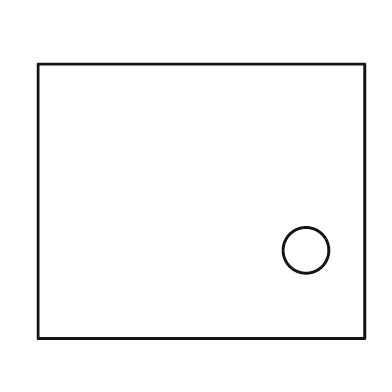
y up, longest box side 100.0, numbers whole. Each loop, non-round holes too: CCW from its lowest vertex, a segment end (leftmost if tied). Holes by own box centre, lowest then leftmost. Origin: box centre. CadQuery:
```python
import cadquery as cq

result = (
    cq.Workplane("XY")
    .moveTo(-50.0, -42.0)
    .lineTo(50.0, -42.0)
    .lineTo(50.0, 42.0)
    .lineTo(-50.0, 42.0)
    .close()
    .moveTo(32.0, -15.0)
    .circle(7.0)
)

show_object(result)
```